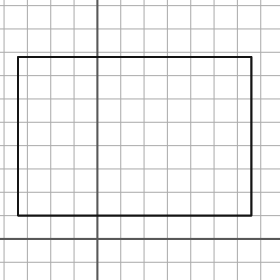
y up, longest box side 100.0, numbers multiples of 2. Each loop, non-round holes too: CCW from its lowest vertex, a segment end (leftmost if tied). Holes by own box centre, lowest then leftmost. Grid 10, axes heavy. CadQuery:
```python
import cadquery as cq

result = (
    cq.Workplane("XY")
    .moveTo(-34.0, 10.0)
    .lineTo(66.0, 10.0)
    .lineTo(66.0, 78.0)
    .lineTo(-34.0, 78.0)
    .close()
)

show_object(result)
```